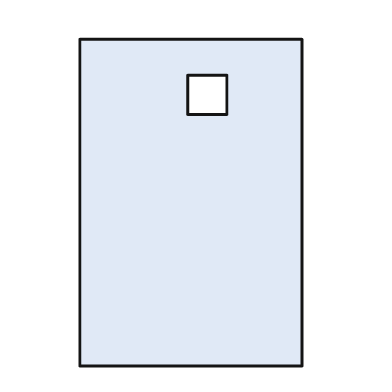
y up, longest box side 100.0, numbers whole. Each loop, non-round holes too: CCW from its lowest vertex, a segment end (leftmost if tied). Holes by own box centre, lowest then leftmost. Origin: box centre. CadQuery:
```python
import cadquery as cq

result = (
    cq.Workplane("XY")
    .moveTo(-34.0, -50.0)
    .lineTo(34.0, -50.0)
    .lineTo(34.0, 50.0)
    .lineTo(-34.0, 50.0)
    .close()
    .moveTo(-1.0, 27.0)
    .lineTo(11.0, 27.0)
    .lineTo(11.0, 39.0)
    .lineTo(-1.0, 39.0)
    .close()
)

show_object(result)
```